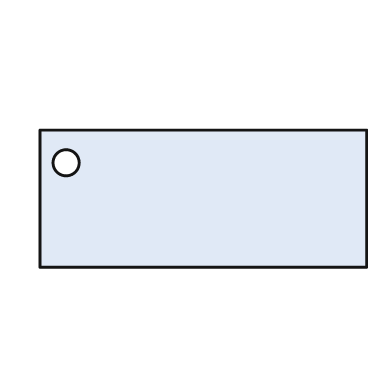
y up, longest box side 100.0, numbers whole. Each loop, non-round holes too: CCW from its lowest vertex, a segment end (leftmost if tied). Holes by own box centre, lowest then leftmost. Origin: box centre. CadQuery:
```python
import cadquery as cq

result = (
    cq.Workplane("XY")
    .moveTo(-50.0, -21.0)
    .lineTo(50.0, -21.0)
    .lineTo(50.0, 21.0)
    .lineTo(-50.0, 21.0)
    .close()
    .moveTo(-42.0, 11.0)
    .circle(4.0)
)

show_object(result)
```